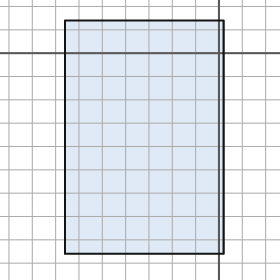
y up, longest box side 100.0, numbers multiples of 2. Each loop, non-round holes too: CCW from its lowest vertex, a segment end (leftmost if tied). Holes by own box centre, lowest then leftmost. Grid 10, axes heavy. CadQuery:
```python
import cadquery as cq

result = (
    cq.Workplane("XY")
    .moveTo(-66.0, -86.0)
    .lineTo(2.0, -86.0)
    .lineTo(2.0, 14.0)
    .lineTo(-66.0, 14.0)
    .close()
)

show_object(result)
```